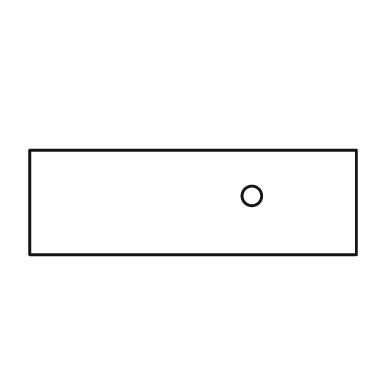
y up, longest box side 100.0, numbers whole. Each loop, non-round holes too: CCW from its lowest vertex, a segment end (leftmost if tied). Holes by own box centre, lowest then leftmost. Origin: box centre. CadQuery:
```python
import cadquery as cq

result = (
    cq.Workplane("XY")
    .moveTo(-50.0, -16.0)
    .lineTo(50.0, -16.0)
    .lineTo(50.0, 16.0)
    .lineTo(-50.0, 16.0)
    .close()
    .moveTo(18.0, 2.0)
    .circle(3.0)
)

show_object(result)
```